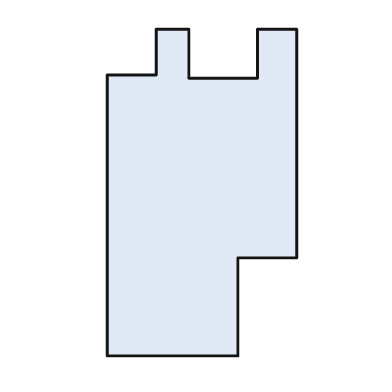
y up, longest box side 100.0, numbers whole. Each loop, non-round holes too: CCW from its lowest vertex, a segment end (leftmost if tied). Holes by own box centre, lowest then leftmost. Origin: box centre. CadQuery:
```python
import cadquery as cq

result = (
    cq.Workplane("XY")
    .moveTo(-29.0, -50.0)
    .lineTo(11.0, -50.0)
    .lineTo(11.0, -20.0)
    .lineTo(29.0, -20.0)
    .lineTo(29.0, 50.0)
    .lineTo(17.0, 50.0)
    .lineTo(17.0, 35.0)
    .lineTo(-4.0, 35.0)
    .lineTo(-4.0, 50.0)
    .lineTo(-14.0, 50.0)
    .lineTo(-14.0, 36.0)
    .lineTo(-29.0, 36.0)
    .close()
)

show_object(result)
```